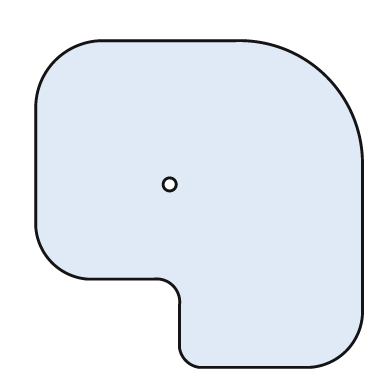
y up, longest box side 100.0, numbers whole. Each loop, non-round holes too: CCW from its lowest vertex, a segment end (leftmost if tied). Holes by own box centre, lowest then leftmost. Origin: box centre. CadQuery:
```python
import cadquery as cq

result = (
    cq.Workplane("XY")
    .moveTo(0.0, -50.0)
    .lineTo(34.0, -50.0)
    .threePointArc((45.0, -45.0), (50.0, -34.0))
    .lineTo(50.0, 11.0)
    .threePointArc((39.0, 39.0), (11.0, 50.0))
    .lineTo(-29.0, 50.0)
    .threePointArc((-44.0, 44.0), (-50.0, 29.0))
    .lineTo(-50.0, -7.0)
    .threePointArc((-45.0, -18.0), (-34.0, -23.0))
    .lineTo(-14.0, -23.0)
    .threePointArc((-8.0, -25.0), (-6.0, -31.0))
    .lineTo(-6.0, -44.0)
    .threePointArc((-4.0, -48.0), (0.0, -50.0))
    .close()
    .moveTo(-9.0, 6.0)
    .circle(2.0)
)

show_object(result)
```